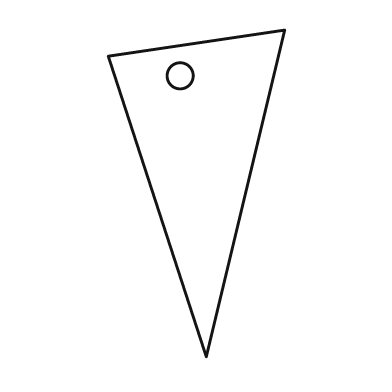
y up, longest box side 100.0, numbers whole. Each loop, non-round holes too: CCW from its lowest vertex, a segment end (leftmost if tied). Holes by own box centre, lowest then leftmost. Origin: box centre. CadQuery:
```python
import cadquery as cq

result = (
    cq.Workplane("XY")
    .moveTo(3.0, -50.0)
    .lineTo(27.0, 50.0)
    .lineTo(-27.0, 42.0)
    .close()
    .moveTo(-5.0, 36.0)
    .circle(4.0)
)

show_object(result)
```